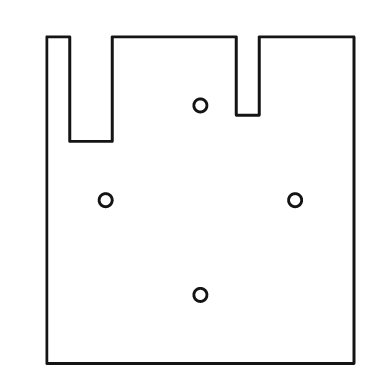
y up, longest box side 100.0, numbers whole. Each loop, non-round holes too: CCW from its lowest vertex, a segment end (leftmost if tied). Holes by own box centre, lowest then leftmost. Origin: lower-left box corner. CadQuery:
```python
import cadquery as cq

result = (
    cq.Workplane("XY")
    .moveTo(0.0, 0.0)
    .lineTo(94.0, 0.0)
    .lineTo(94.0, 100.0)
    .lineTo(65.0, 100.0)
    .lineTo(65.0, 76.0)
    .lineTo(58.0, 76.0)
    .lineTo(58.0, 100.0)
    .lineTo(20.0, 100.0)
    .lineTo(20.0, 68.0)
    .lineTo(7.0, 68.0)
    .lineTo(7.0, 100.0)
    .lineTo(0.0, 100.0)
    .close()
    .moveTo(47.0, 21.0)
    .circle(2.0)
    .moveTo(18.0, 50.0)
    .circle(2.0)
    .moveTo(76.0, 50.0)
    .circle(2.0)
    .moveTo(47.0, 79.0)
    .circle(2.0)
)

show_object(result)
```